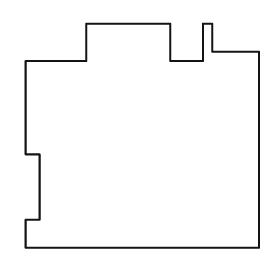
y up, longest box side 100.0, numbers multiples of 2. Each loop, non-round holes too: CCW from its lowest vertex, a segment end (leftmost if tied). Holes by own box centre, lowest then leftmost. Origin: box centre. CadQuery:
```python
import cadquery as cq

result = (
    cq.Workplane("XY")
    .moveTo(-50.0, -48.0)
    .lineTo(50.0, -48.0)
    .lineTo(50.0, 36.0)
    .lineTo(30.0, 36.0)
    .lineTo(30.0, 48.0)
    .lineTo(26.0, 48.0)
    .lineTo(26.0, 32.0)
    .lineTo(12.0, 32.0)
    .lineTo(12.0, 48.0)
    .lineTo(-24.0, 48.0)
    .lineTo(-24.0, 32.0)
    .lineTo(-50.0, 32.0)
    .lineTo(-50.0, -8.0)
    .lineTo(-44.0, -8.0)
    .lineTo(-44.0, -36.0)
    .lineTo(-50.0, -36.0)
    .close()
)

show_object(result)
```